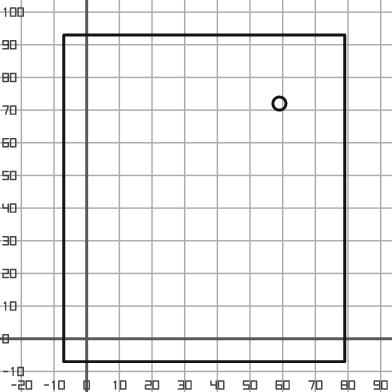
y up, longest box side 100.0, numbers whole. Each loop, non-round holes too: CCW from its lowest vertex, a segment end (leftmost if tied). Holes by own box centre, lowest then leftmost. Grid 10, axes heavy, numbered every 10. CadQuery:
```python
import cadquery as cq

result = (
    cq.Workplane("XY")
    .moveTo(-7.0, -7.0)
    .lineTo(79.0, -7.0)
    .lineTo(79.0, 93.0)
    .lineTo(-7.0, 93.0)
    .close()
    .moveTo(59.0, 72.0)
    .circle(2.0)
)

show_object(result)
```